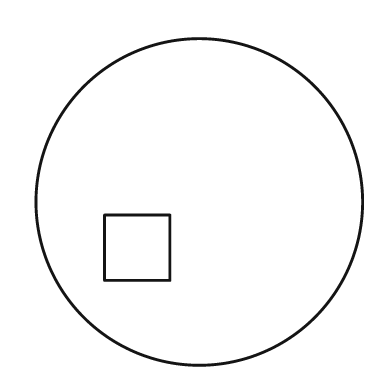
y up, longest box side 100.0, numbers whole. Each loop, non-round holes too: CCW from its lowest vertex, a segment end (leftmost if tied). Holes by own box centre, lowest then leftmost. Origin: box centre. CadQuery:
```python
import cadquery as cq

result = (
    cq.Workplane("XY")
    .moveTo(0.0, 0.0)
    .circle(50.0)
    .moveTo(-29.0, -24.0)
    .lineTo(-9.0, -24.0)
    .lineTo(-9.0, -4.0)
    .lineTo(-29.0, -4.0)
    .close()
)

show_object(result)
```